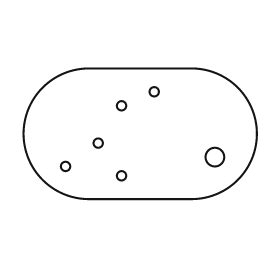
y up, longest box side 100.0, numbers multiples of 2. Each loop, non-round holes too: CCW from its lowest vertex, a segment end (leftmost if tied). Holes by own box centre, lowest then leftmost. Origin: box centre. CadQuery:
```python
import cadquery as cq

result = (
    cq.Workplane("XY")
    .moveTo(-22.0, -28.0)
    .lineTo(22.0, -28.0)
    .threePointArc((50.0, 0.0), (22.0, 28.0))
    .lineTo(-22.0, 28.0)
    .threePointArc((-50.0, 0.0), (-22.0, -28.0))
    .close()
    .moveTo(-8.0, -18.0)
    .circle(2.0)
    .moveTo(-32.0, -14.0)
    .circle(2.0)
    .moveTo(32.0, -10.0)
    .circle(4.0)
    .moveTo(-18.0, -4.0)
    .circle(2.0)
    .moveTo(-8.0, 12.0)
    .circle(2.0)
    .moveTo(6.0, 18.0)
    .circle(2.0)
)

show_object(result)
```